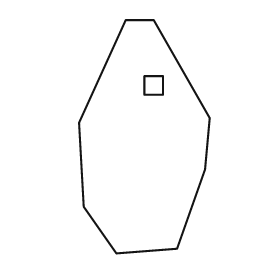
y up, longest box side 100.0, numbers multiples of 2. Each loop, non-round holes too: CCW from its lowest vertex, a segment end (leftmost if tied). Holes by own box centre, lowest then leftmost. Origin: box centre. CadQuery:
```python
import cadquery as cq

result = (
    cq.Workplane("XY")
    .moveTo(-12.0, -50.0)
    .lineTo(14.0, -48.0)
    .lineTo(26.0, -14.0)
    .lineTo(28.0, 8.0)
    .lineTo(4.0, 50.0)
    .lineTo(-8.0, 50.0)
    .lineTo(-28.0, 6.0)
    .lineTo(-26.0, -30.0)
    .close()
    .moveTo(0.0, 18.0)
    .lineTo(8.0, 18.0)
    .lineTo(8.0, 26.0)
    .lineTo(0.0, 26.0)
    .close()
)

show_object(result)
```